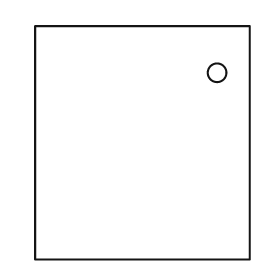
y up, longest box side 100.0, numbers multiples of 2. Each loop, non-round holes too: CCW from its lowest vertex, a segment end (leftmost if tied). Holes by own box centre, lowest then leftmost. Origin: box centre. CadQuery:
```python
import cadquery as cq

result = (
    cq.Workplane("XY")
    .moveTo(-46.0, -50.0)
    .lineTo(46.0, -50.0)
    .lineTo(46.0, 50.0)
    .lineTo(-46.0, 50.0)
    .close()
    .moveTo(32.0, 30.0)
    .circle(4.0)
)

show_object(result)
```